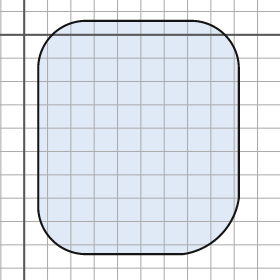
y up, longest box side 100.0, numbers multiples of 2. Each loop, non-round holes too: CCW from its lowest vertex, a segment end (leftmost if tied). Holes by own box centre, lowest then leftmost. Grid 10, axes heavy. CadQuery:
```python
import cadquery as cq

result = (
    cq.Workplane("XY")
    .moveTo(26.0, -94.0)
    .lineTo(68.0, -94.0)
    .threePointArc((84.0, -86.0), (92.0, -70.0))
    .lineTo(92.0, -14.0)
    .threePointArc((86.0, 0.0), (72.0, 6.0))
    .lineTo(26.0, 6.0)
    .threePointArc((12.0, 0.0), (6.0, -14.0))
    .lineTo(6.0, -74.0)
    .threePointArc((12.0, -88.0), (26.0, -94.0))
    .close()
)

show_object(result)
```